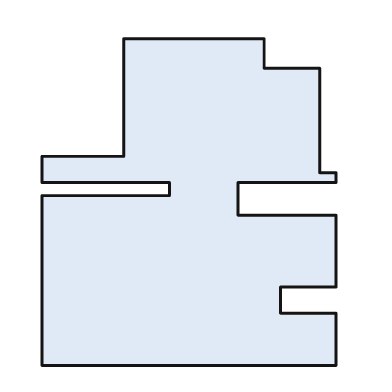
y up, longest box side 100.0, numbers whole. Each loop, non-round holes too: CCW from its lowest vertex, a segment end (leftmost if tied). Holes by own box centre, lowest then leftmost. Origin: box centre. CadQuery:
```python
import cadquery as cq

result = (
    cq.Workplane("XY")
    .moveTo(-45.0, -50.0)
    .lineTo(45.0, -50.0)
    .lineTo(45.0, -34.0)
    .lineTo(28.0, -34.0)
    .lineTo(28.0, -26.0)
    .lineTo(45.0, -26.0)
    .lineTo(45.0, -4.0)
    .lineTo(15.0, -4.0)
    .lineTo(15.0, 6.0)
    .lineTo(45.0, 6.0)
    .lineTo(45.0, 9.0)
    .lineTo(40.0, 9.0)
    .lineTo(40.0, 41.0)
    .lineTo(23.0, 41.0)
    .lineTo(23.0, 50.0)
    .lineTo(-20.0, 50.0)
    .lineTo(-20.0, 14.0)
    .lineTo(-45.0, 14.0)
    .lineTo(-45.0, 6.0)
    .lineTo(-6.0, 6.0)
    .lineTo(-6.0, 2.0)
    .lineTo(-45.0, 2.0)
    .close()
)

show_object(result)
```